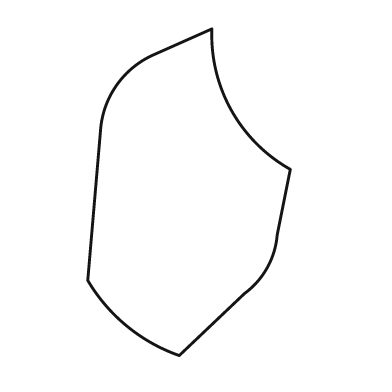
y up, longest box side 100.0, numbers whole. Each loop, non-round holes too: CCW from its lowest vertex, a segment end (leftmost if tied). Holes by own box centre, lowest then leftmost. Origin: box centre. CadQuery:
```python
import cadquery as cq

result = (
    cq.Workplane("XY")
    .moveTo(-3.0, -50.0)
    .lineTo(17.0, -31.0)
    .threePointArc((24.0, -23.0), (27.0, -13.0))
    .lineTo(31.0, 7.0)
    .threePointArc((13.0, 25.0), (7.0, 50.0))
    .lineTo(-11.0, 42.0)
    .threePointArc((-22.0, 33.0), (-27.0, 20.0))
    .lineTo(-31.0, -27.0)
    .threePointArc((-19.0, -41.0), (-3.0, -50.0))
    .close()
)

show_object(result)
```